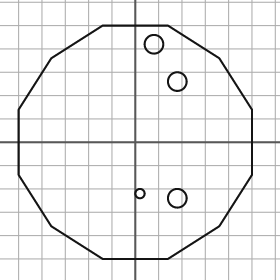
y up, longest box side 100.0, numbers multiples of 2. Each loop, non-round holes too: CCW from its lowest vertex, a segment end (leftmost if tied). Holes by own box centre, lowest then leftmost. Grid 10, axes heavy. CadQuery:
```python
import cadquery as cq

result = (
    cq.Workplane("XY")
    .moveTo(-14.0, -50.0)
    .lineTo(14.0, -50.0)
    .lineTo(36.0, -36.0)
    .lineTo(50.0, -14.0)
    .lineTo(50.0, 14.0)
    .lineTo(36.0, 36.0)
    .lineTo(14.0, 50.0)
    .lineTo(-14.0, 50.0)
    .lineTo(-36.0, 36.0)
    .lineTo(-50.0, 14.0)
    .lineTo(-50.0, -14.0)
    .lineTo(-36.0, -36.0)
    .close()
    .moveTo(18.0, -24.0)
    .circle(4.0)
    .moveTo(2.0, -22.0)
    .circle(2.0)
    .moveTo(18.0, 26.0)
    .circle(4.0)
    .moveTo(8.0, 42.0)
    .circle(4.0)
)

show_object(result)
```